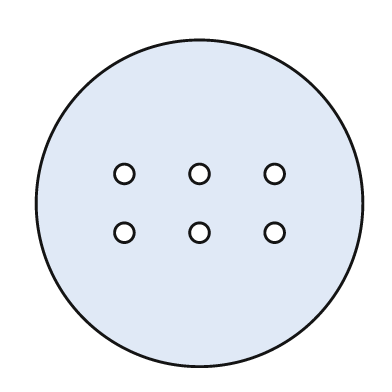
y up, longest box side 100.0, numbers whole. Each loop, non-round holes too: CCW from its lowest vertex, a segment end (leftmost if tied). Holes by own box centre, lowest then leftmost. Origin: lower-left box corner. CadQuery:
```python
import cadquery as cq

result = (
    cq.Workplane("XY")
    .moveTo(50.0, 50.0)
    .circle(50.0)
    .moveTo(27.0, 41.0)
    .circle(3.0)
    .moveTo(50.0, 41.0)
    .circle(3.0)
    .moveTo(73.0, 41.0)
    .circle(3.0)
    .moveTo(27.0, 59.0)
    .circle(3.0)
    .moveTo(50.0, 59.0)
    .circle(3.0)
    .moveTo(73.0, 59.0)
    .circle(3.0)
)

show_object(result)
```